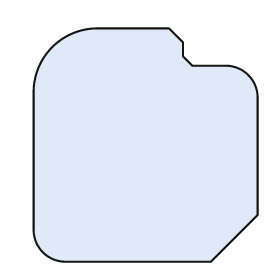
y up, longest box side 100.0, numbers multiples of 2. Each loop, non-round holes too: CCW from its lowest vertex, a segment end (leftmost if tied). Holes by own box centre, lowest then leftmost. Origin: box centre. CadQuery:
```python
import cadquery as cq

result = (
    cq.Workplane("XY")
    .moveTo(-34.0, -50.0)
    .lineTo(28.0, -50.0)
    .lineTo(48.0, -30.0)
    .lineTo(48.0, 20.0)
    .threePointArc((44.0, 30.0), (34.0, 34.0))
    .lineTo(20.0, 34.0)
    .lineTo(16.0, 38.0)
    .lineTo(16.0, 44.0)
    .lineTo(10.0, 50.0)
    .lineTo(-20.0, 50.0)
    .threePointArc((-40.0, 42.0), (-48.0, 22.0))
    .lineTo(-48.0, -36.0)
    .threePointArc((-44.0, -46.0), (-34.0, -50.0))
    .close()
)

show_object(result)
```